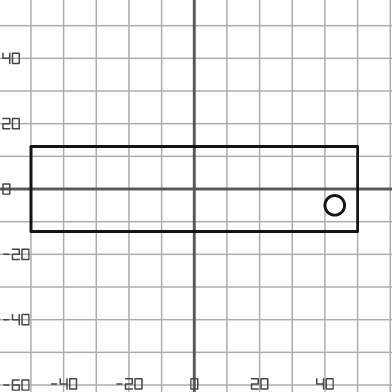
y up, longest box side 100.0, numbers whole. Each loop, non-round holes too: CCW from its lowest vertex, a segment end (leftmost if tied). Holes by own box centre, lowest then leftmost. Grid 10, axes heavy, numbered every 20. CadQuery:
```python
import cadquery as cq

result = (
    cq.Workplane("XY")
    .moveTo(-50.0, -13.0)
    .lineTo(50.0, -13.0)
    .lineTo(50.0, 13.0)
    .lineTo(-50.0, 13.0)
    .close()
    .moveTo(43.0, -5.0)
    .circle(3.0)
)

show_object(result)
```